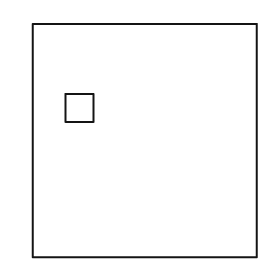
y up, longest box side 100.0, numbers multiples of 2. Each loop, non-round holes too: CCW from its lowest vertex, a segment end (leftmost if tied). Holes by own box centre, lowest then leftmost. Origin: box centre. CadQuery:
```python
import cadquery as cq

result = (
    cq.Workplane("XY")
    .moveTo(-48.0, -50.0)
    .lineTo(48.0, -50.0)
    .lineTo(48.0, 50.0)
    .lineTo(-48.0, 50.0)
    .close()
    .moveTo(-34.0, 8.0)
    .lineTo(-22.0, 8.0)
    .lineTo(-22.0, 20.0)
    .lineTo(-34.0, 20.0)
    .close()
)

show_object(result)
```